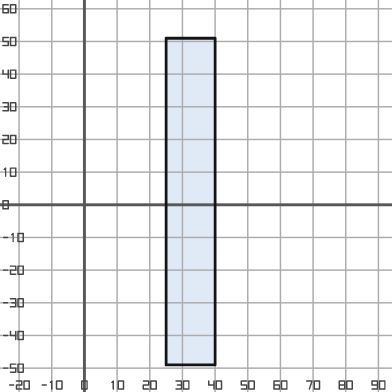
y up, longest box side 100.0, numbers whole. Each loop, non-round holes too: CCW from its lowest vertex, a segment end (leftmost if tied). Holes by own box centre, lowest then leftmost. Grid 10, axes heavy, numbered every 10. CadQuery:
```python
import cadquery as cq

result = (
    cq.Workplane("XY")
    .moveTo(25.0, -49.0)
    .lineTo(40.0, -49.0)
    .lineTo(40.0, 51.0)
    .lineTo(25.0, 51.0)
    .close()
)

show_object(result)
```